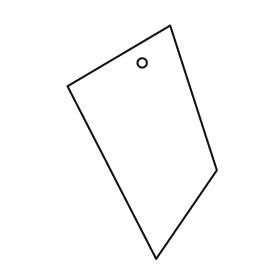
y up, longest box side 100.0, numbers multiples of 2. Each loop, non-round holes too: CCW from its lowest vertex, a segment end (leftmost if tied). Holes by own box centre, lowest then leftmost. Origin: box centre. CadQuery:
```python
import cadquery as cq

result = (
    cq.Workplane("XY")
    .moveTo(6.0, -50.0)
    .lineTo(32.0, -12.0)
    .lineTo(12.0, 50.0)
    .lineTo(-32.0, 24.0)
    .close()
    .moveTo(0.0, 34.0)
    .circle(2.0)
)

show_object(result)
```